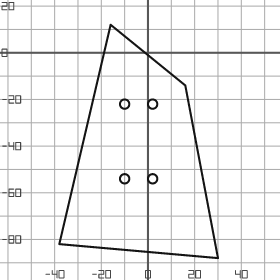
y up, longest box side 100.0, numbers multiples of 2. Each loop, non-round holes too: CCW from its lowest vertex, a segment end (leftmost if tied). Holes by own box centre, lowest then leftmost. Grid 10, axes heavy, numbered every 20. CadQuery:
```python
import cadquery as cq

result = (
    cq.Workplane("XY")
    .moveTo(30.0, -88.0)
    .lineTo(16.0, -14.0)
    .lineTo(-16.0, 12.0)
    .lineTo(-38.0, -82.0)
    .close()
    .moveTo(-10.0, -54.0)
    .circle(2.0)
    .moveTo(2.0, -54.0)
    .circle(2.0)
    .moveTo(-10.0, -22.0)
    .circle(2.0)
    .moveTo(2.0, -22.0)
    .circle(2.0)
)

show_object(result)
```